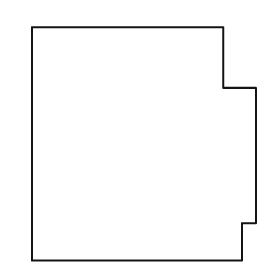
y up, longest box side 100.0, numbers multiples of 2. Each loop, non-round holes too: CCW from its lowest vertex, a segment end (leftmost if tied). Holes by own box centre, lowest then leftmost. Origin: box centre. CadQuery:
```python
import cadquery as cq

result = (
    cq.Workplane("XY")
    .moveTo(-48.0, -50.0)
    .lineTo(42.0, -50.0)
    .lineTo(42.0, -34.0)
    .lineTo(48.0, -34.0)
    .lineTo(48.0, 24.0)
    .lineTo(34.0, 24.0)
    .lineTo(34.0, 50.0)
    .lineTo(-48.0, 50.0)
    .close()
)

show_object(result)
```